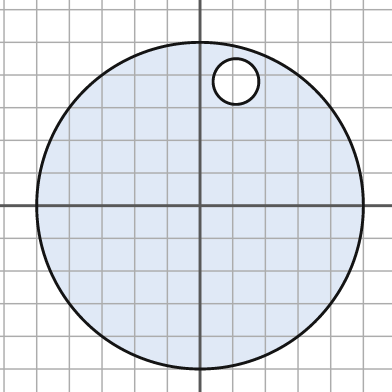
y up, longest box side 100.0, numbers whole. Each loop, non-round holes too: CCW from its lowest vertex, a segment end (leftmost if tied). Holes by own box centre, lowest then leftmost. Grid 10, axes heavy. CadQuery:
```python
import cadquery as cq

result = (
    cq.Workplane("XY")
    .moveTo(0.0, 0.0)
    .circle(50.0)
    .moveTo(11.0, 38.0)
    .circle(7.0)
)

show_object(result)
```